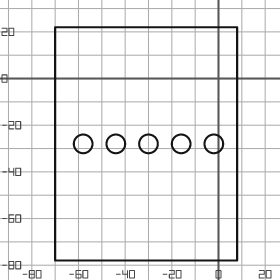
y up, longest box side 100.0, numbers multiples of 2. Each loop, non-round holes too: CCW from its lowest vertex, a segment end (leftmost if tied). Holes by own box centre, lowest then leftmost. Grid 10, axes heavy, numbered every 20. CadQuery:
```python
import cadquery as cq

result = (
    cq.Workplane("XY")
    .moveTo(-70.0, -78.0)
    .lineTo(8.0, -78.0)
    .lineTo(8.0, 22.0)
    .lineTo(-70.0, 22.0)
    .close()
    .moveTo(-58.0, -28.0)
    .circle(4.0)
    .moveTo(-44.0, -28.0)
    .circle(4.0)
    .moveTo(-30.0, -28.0)
    .circle(4.0)
    .moveTo(-16.0, -28.0)
    .circle(4.0)
    .moveTo(-2.0, -28.0)
    .circle(4.0)
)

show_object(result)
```